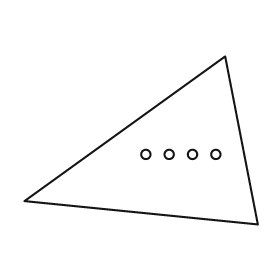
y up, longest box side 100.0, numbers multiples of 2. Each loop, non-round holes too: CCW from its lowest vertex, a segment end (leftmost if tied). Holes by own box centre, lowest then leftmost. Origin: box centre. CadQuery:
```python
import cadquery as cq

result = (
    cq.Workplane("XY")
    .moveTo(50.0, -36.0)
    .lineTo(36.0, 36.0)
    .lineTo(-50.0, -26.0)
    .close()
    .moveTo(2.0, -6.0)
    .circle(2.0)
    .moveTo(12.0, -6.0)
    .circle(2.0)
    .moveTo(22.0, -6.0)
    .circle(2.0)
    .moveTo(32.0, -6.0)
    .circle(2.0)
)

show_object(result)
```